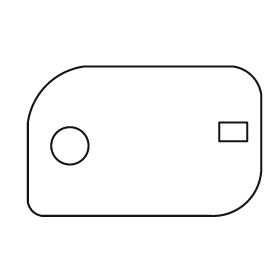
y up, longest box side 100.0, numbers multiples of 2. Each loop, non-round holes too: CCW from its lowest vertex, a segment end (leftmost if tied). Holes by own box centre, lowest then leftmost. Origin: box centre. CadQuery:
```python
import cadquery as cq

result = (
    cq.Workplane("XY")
    .moveTo(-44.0, -32.0)
    .lineTo(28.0, -32.0)
    .threePointArc((44.0, -26.0), (50.0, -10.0))
    .lineTo(50.0, 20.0)
    .threePointArc((46.0, 28.0), (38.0, 32.0))
    .lineTo(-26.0, 32.0)
    .threePointArc((-42.0, 24.0), (-50.0, 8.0))
    .lineTo(-50.0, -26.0)
    .threePointArc((-48.0, -30.0), (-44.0, -32.0))
    .close()
    .moveTo(-32.0, -2.0)
    .circle(8.0)
    .moveTo(32.0, 0.0)
    .lineTo(44.0, 0.0)
    .lineTo(44.0, 8.0)
    .lineTo(32.0, 8.0)
    .close()
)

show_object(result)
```